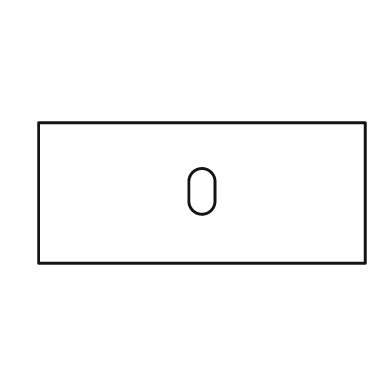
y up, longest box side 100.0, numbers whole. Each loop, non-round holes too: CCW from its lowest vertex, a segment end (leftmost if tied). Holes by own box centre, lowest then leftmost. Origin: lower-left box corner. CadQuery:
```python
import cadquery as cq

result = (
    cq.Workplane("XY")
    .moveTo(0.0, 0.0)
    .lineTo(100.0, 0.0)
    .lineTo(100.0, 43.0)
    .lineTo(0.0, 43.0)
    .close()
    .moveTo(46.0, 19.0)
    .threePointArc((50.0, 15.0), (54.0, 19.0))
    .lineTo(54.0, 25.0)
    .threePointArc((50.0, 29.0), (46.0, 25.0))
    .close()
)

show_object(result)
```